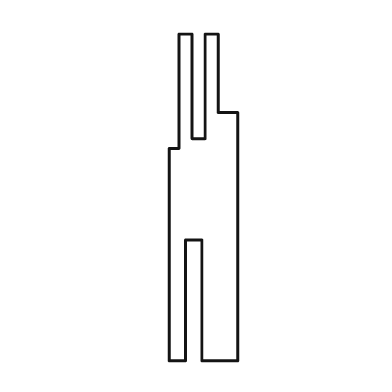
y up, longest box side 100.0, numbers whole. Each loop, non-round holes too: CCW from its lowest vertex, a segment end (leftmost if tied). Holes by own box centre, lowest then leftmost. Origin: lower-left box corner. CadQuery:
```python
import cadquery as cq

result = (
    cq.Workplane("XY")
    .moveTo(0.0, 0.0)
    .lineTo(5.0, 0.0)
    .lineTo(5.0, 37.0)
    .lineTo(10.0, 37.0)
    .lineTo(10.0, 0.0)
    .lineTo(21.0, 0.0)
    .lineTo(21.0, 76.0)
    .lineTo(15.0, 76.0)
    .lineTo(15.0, 100.0)
    .lineTo(11.0, 100.0)
    .lineTo(11.0, 68.0)
    .lineTo(7.0, 68.0)
    .lineTo(7.0, 100.0)
    .lineTo(3.0, 100.0)
    .lineTo(3.0, 65.0)
    .lineTo(0.0, 65.0)
    .close()
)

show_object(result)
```